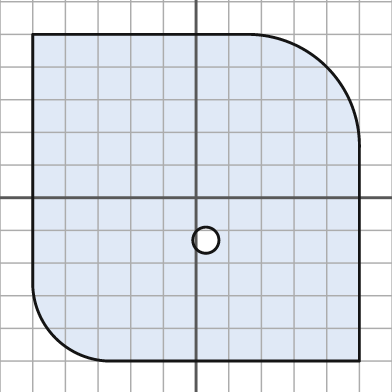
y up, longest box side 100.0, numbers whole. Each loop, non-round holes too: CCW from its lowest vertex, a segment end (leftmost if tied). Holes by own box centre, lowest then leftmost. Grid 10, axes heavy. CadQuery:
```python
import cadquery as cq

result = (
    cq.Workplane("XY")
    .moveTo(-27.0, -50.0)
    .lineTo(50.0, -50.0)
    .lineTo(50.0, 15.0)
    .threePointArc((40.0, 40.0), (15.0, 50.0))
    .lineTo(-50.0, 50.0)
    .lineTo(-50.0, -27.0)
    .threePointArc((-43.0, -43.0), (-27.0, -50.0))
    .close()
    .moveTo(3.0, -13.0)
    .circle(4.0)
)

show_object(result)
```